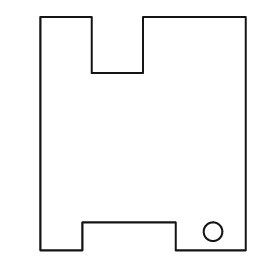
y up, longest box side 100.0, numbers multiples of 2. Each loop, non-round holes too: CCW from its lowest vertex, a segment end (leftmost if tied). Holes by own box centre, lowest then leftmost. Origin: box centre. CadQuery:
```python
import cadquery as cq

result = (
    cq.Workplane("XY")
    .moveTo(-44.0, -50.0)
    .lineTo(-26.0, -50.0)
    .lineTo(-26.0, -38.0)
    .lineTo(14.0, -38.0)
    .lineTo(14.0, -50.0)
    .lineTo(44.0, -50.0)
    .lineTo(44.0, 50.0)
    .lineTo(0.0, 50.0)
    .lineTo(0.0, 26.0)
    .lineTo(-22.0, 26.0)
    .lineTo(-22.0, 50.0)
    .lineTo(-44.0, 50.0)
    .close()
    .moveTo(30.0, -42.0)
    .circle(4.0)
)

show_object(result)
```